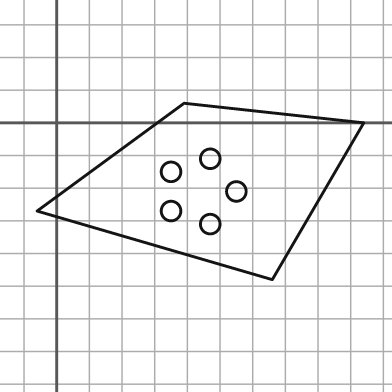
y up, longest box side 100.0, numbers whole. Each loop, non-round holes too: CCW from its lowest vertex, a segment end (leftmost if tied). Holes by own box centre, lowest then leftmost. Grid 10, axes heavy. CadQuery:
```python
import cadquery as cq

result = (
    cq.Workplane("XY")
    .moveTo(66.0, -48.0)
    .lineTo(94.0, 0.0)
    .lineTo(39.0, 6.0)
    .lineTo(-6.0, -27.0)
    .close()
    .moveTo(47.0, -31.0)
    .circle(3.0)
    .moveTo(35.0, -27.0)
    .circle(3.0)
    .moveTo(55.0, -21.0)
    .circle(3.0)
    .moveTo(35.0, -15.0)
    .circle(3.0)
    .moveTo(47.0, -11.0)
    .circle(3.0)
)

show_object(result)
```